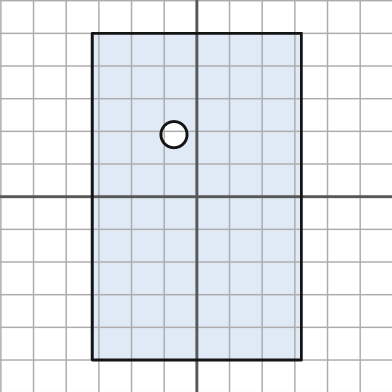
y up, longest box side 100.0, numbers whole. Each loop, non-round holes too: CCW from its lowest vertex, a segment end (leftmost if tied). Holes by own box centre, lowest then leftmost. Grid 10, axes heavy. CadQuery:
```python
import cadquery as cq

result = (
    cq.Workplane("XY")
    .moveTo(-32.0, -50.0)
    .lineTo(32.0, -50.0)
    .lineTo(32.0, 50.0)
    .lineTo(-32.0, 50.0)
    .close()
    .moveTo(-7.0, 19.0)
    .circle(4.0)
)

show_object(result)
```